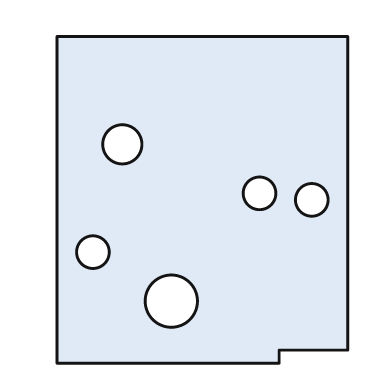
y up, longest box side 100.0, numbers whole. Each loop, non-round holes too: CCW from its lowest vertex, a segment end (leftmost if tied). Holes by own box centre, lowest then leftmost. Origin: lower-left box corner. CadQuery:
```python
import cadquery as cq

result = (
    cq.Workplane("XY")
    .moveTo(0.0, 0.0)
    .lineTo(68.0, 0.0)
    .lineTo(68.0, 4.0)
    .lineTo(89.0, 4.0)
    .lineTo(89.0, 100.0)
    .lineTo(0.0, 100.0)
    .close()
    .moveTo(35.0, 19.0)
    .circle(8.0)
    .moveTo(11.0, 34.0)
    .circle(5.0)
    .moveTo(78.0, 50.0)
    .circle(5.0)
    .moveTo(62.0, 52.0)
    .circle(5.0)
    .moveTo(20.0, 67.0)
    .circle(6.0)
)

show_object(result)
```